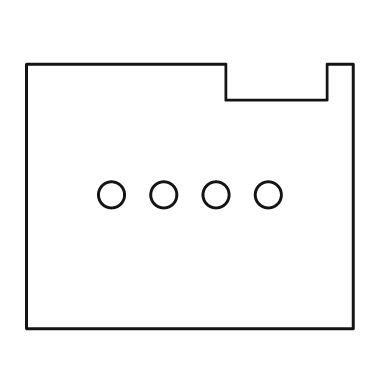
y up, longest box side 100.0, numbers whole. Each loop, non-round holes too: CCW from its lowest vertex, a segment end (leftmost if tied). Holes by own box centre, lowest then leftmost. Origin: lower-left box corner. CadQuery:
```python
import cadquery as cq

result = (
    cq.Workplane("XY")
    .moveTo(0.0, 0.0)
    .lineTo(100.0, 0.0)
    .lineTo(100.0, 81.0)
    .lineTo(92.0, 81.0)
    .lineTo(92.0, 70.0)
    .lineTo(61.0, 70.0)
    .lineTo(61.0, 81.0)
    .lineTo(0.0, 81.0)
    .close()
    .moveTo(26.0, 41.0)
    .circle(4.0)
    .moveTo(42.0, 41.0)
    .circle(4.0)
    .moveTo(58.0, 41.0)
    .circle(4.0)
    .moveTo(74.0, 41.0)
    .circle(4.0)
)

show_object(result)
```